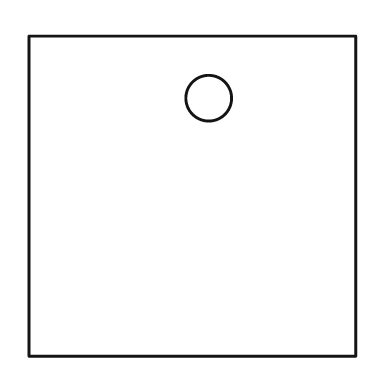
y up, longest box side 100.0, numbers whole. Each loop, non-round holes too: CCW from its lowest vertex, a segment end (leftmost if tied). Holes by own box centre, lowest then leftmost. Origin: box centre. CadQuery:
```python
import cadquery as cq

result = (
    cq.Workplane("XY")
    .moveTo(-50.0, -49.0)
    .lineTo(50.0, -49.0)
    .lineTo(50.0, 49.0)
    .lineTo(-50.0, 49.0)
    .close()
    .moveTo(5.0, 30.0)
    .circle(7.0)
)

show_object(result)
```